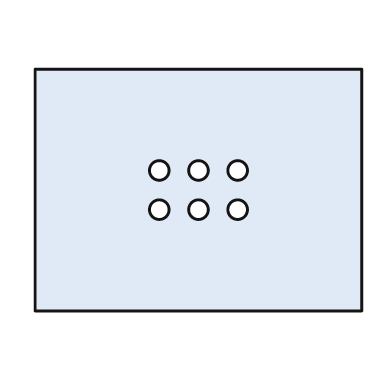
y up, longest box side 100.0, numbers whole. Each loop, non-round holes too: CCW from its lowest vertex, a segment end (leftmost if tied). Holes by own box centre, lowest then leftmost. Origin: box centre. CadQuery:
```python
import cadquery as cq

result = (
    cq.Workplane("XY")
    .moveTo(-50.0, -37.0)
    .lineTo(50.0, -37.0)
    .lineTo(50.0, 37.0)
    .lineTo(-50.0, 37.0)
    .close()
    .moveTo(-12.0, -6.0)
    .circle(3.0)
    .moveTo(0.0, -6.0)
    .circle(3.0)
    .moveTo(12.0, -6.0)
    .circle(3.0)
    .moveTo(-12.0, 6.0)
    .circle(3.0)
    .moveTo(0.0, 6.0)
    .circle(3.0)
    .moveTo(12.0, 6.0)
    .circle(3.0)
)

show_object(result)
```